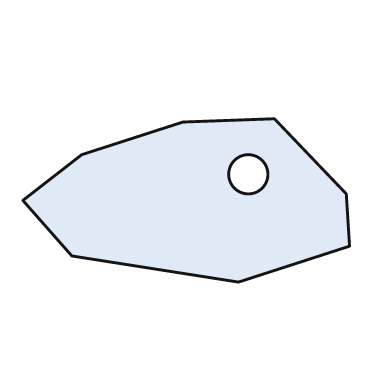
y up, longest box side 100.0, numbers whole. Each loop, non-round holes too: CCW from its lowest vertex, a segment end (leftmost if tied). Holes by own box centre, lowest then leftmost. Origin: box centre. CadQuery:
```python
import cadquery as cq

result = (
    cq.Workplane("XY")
    .moveTo(16.0, -25.0)
    .lineTo(50.0, -14.0)
    .lineTo(49.0, 2.0)
    .lineTo(27.0, 25.0)
    .lineTo(-1.0, 24.0)
    .lineTo(-32.0, 14.0)
    .lineTo(-50.0, 0.0)
    .lineTo(-35.0, -17.0)
    .close()
    .moveTo(19.0, 8.0)
    .circle(6.0)
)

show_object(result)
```